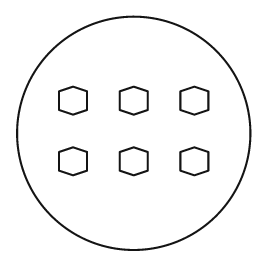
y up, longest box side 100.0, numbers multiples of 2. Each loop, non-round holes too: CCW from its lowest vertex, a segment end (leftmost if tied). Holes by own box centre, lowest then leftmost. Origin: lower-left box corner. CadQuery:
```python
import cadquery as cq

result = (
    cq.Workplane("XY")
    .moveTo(50.0, 50.0)
    .circle(50.0)
    .moveTo(24.0, 32.0)
    .lineTo(30.0, 34.0)
    .lineTo(30.0, 42.0)
    .lineTo(24.0, 44.0)
    .lineTo(18.0, 42.0)
    .lineTo(18.0, 34.0)
    .close()
    .moveTo(50.0, 32.0)
    .lineTo(56.0, 34.0)
    .lineTo(56.0, 42.0)
    .lineTo(50.0, 44.0)
    .lineTo(44.0, 42.0)
    .lineTo(44.0, 34.0)
    .close()
    .moveTo(76.0, 32.0)
    .lineTo(82.0, 34.0)
    .lineTo(82.0, 42.0)
    .lineTo(76.0, 44.0)
    .lineTo(70.0, 42.0)
    .lineTo(70.0, 34.0)
    .close()
    .moveTo(24.0, 58.0)
    .lineTo(30.0, 60.0)
    .lineTo(30.0, 68.0)
    .lineTo(24.0, 70.0)
    .lineTo(18.0, 68.0)
    .lineTo(18.0, 60.0)
    .close()
    .moveTo(50.0, 58.0)
    .lineTo(56.0, 60.0)
    .lineTo(56.0, 68.0)
    .lineTo(50.0, 70.0)
    .lineTo(44.0, 68.0)
    .lineTo(44.0, 60.0)
    .close()
    .moveTo(76.0, 58.0)
    .lineTo(82.0, 60.0)
    .lineTo(82.0, 68.0)
    .lineTo(76.0, 70.0)
    .lineTo(70.0, 68.0)
    .lineTo(70.0, 60.0)
    .close()
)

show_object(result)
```